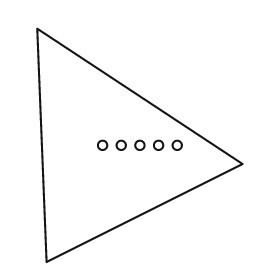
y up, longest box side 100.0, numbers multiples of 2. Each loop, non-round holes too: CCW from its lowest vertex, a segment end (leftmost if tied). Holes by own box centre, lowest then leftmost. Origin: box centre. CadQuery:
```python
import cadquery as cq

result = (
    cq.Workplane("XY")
    .moveTo(-40.0, -50.0)
    .lineTo(44.0, -8.0)
    .lineTo(-44.0, 50.0)
    .close()
    .moveTo(-16.0, 0.0)
    .circle(2.0)
    .moveTo(-8.0, 0.0)
    .circle(2.0)
    .moveTo(0.0, 0.0)
    .circle(2.0)
    .moveTo(8.0, 0.0)
    .circle(2.0)
    .moveTo(16.0, 0.0)
    .circle(2.0)
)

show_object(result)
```